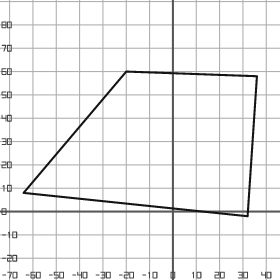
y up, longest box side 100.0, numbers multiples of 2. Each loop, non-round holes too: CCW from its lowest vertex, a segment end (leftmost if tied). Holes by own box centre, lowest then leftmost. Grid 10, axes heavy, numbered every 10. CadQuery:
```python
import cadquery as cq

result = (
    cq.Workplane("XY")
    .moveTo(32.0, -2.0)
    .lineTo(36.0, 58.0)
    .lineTo(-20.0, 60.0)
    .lineTo(-64.0, 8.0)
    .close()
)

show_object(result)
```